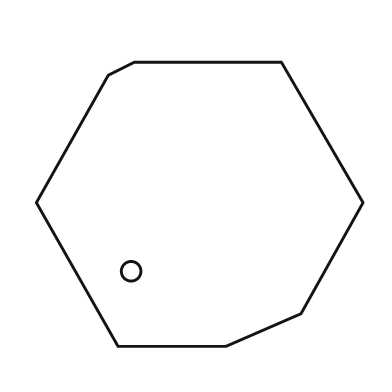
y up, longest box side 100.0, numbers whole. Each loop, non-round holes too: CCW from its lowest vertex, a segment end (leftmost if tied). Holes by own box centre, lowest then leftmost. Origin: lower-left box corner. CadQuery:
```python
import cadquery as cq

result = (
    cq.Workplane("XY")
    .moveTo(25.0, 0.0)
    .lineTo(58.0, 0.0)
    .lineTo(81.0, 10.0)
    .lineTo(100.0, 44.0)
    .lineTo(75.0, 87.0)
    .lineTo(30.0, 87.0)
    .lineTo(22.0, 83.0)
    .lineTo(0.0, 44.0)
    .close()
    .moveTo(29.0, 23.0)
    .circle(3.0)
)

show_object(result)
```